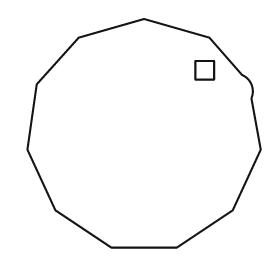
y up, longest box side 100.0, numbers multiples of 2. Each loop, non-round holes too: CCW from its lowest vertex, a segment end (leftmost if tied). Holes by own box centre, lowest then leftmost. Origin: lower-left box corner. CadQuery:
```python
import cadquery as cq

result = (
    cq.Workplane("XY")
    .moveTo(36.0, 0.0)
    .lineTo(64.0, 0.0)
    .lineTo(88.0, 16.0)
    .lineTo(100.0, 42.0)
    .lineTo(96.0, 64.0)
    .threePointArc((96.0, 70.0), (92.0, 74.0))
    .lineTo(78.0, 90.0)
    .lineTo(50.0, 98.0)
    .lineTo(22.0, 90.0)
    .lineTo(4.0, 70.0)
    .lineTo(0.0, 42.0)
    .lineTo(12.0, 16.0)
    .close()
    .moveTo(72.0, 72.0)
    .lineTo(80.0, 72.0)
    .lineTo(80.0, 80.0)
    .lineTo(72.0, 80.0)
    .close()
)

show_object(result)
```